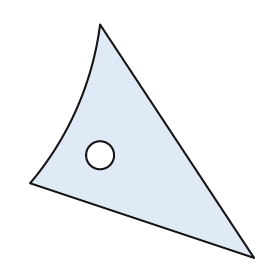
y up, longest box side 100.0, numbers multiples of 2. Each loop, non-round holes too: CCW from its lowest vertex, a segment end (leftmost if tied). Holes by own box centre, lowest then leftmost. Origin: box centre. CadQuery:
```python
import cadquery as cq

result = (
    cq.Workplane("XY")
    .moveTo(48.0, -50.0)
    .lineTo(-18.0, 50.0)
    .threePointArc((-28.0, 14.0), (-48.0, -18.0))
    .close()
    .moveTo(-18.0, -6.0)
    .circle(6.0)
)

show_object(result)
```